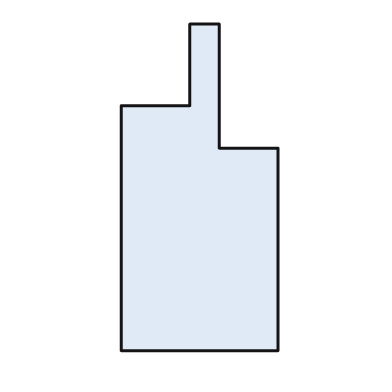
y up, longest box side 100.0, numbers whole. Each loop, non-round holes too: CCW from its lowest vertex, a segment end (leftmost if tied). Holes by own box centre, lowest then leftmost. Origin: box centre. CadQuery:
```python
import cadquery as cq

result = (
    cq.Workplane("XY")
    .moveTo(-24.0, -50.0)
    .lineTo(24.0, -50.0)
    .lineTo(24.0, 12.0)
    .lineTo(6.0, 12.0)
    .lineTo(6.0, 50.0)
    .lineTo(-3.0, 50.0)
    .lineTo(-3.0, 25.0)
    .lineTo(-24.0, 25.0)
    .close()
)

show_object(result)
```